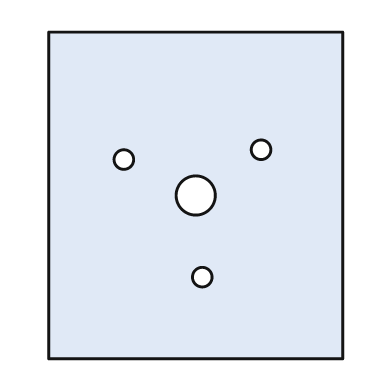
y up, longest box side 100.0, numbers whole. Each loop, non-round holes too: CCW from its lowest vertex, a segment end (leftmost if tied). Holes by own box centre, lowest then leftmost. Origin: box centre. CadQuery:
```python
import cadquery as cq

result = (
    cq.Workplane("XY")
    .moveTo(-45.0, -50.0)
    .lineTo(45.0, -50.0)
    .lineTo(45.0, 50.0)
    .lineTo(-45.0, 50.0)
    .close()
    .moveTo(2.0, -25.0)
    .circle(3.0)
    .moveTo(0.0, 0.0)
    .circle(6.0)
    .moveTo(-22.0, 11.0)
    .circle(3.0)
    .moveTo(20.0, 14.0)
    .circle(3.0)
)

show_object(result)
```